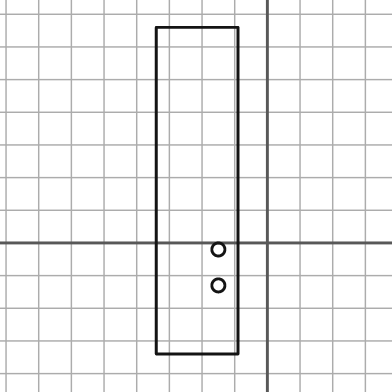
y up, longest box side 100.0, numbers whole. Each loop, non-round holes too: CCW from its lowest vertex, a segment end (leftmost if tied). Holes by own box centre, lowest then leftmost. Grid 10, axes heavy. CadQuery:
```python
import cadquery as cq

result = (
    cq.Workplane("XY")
    .moveTo(-34.0, -34.0)
    .lineTo(-9.0, -34.0)
    .lineTo(-9.0, 66.0)
    .lineTo(-34.0, 66.0)
    .close()
    .moveTo(-15.0, -13.0)
    .circle(2.0)
    .moveTo(-15.0, -2.0)
    .circle(2.0)
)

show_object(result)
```